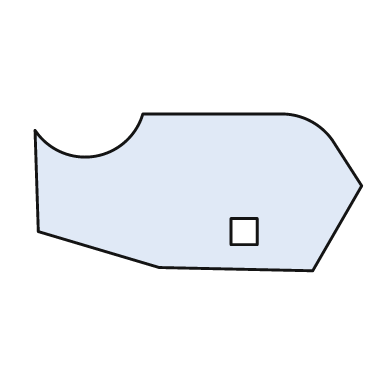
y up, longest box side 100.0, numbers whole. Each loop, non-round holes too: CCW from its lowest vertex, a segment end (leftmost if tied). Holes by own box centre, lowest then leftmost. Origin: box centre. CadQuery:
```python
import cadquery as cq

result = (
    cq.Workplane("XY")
    .moveTo(35.0, -24.0)
    .lineTo(50.0, 2.0)
    .lineTo(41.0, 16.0)
    .threePointArc((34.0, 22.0), (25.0, 24.0))
    .lineTo(-17.0, 24.0)
    .threePointArc((-32.0, 11.0), (-50.0, 19.0))
    .lineTo(-49.0, -12.0)
    .lineTo(-12.0, -23.0)
    .close()
    .moveTo(10.0, -16.0)
    .lineTo(18.0, -16.0)
    .lineTo(18.0, -8.0)
    .lineTo(10.0, -8.0)
    .close()
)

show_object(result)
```